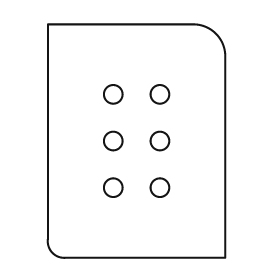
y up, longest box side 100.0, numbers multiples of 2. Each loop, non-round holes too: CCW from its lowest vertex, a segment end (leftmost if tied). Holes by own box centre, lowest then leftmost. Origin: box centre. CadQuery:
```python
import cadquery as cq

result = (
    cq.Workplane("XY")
    .moveTo(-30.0, -50.0)
    .lineTo(38.0, -50.0)
    .lineTo(38.0, 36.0)
    .threePointArc((34.0, 46.0), (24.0, 50.0))
    .lineTo(-38.0, 50.0)
    .lineTo(-38.0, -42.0)
    .threePointArc((-36.0, -48.0), (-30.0, -50.0))
    .close()
    .moveTo(-10.0, -20.0)
    .circle(4.0)
    .moveTo(10.0, -20.0)
    .circle(4.0)
    .moveTo(-10.0, 0.0)
    .circle(4.0)
    .moveTo(10.0, 0.0)
    .circle(4.0)
    .moveTo(-10.0, 20.0)
    .circle(4.0)
    .moveTo(10.0, 20.0)
    .circle(4.0)
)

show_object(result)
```